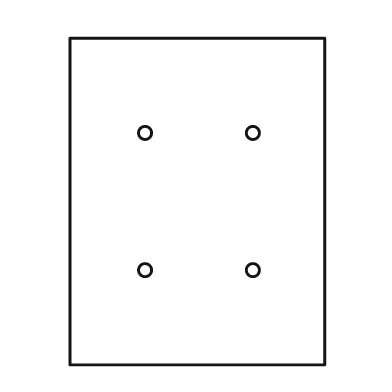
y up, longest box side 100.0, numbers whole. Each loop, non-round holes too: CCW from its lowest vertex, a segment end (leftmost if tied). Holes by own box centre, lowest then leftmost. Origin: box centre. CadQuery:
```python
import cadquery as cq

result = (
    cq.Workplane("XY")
    .moveTo(-39.0, -50.0)
    .lineTo(39.0, -50.0)
    .lineTo(39.0, 50.0)
    .lineTo(-39.0, 50.0)
    .close()
    .moveTo(-16.0, -21.0)
    .circle(2.0)
    .moveTo(17.0, -21.0)
    .circle(2.0)
    .moveTo(-16.0, 21.0)
    .circle(2.0)
    .moveTo(17.0, 21.0)
    .circle(2.0)
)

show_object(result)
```